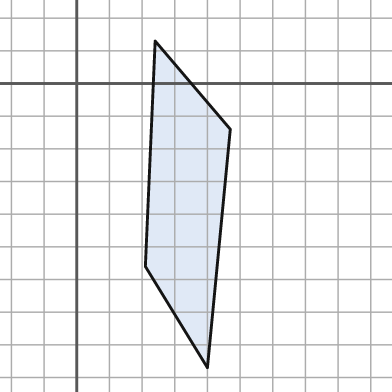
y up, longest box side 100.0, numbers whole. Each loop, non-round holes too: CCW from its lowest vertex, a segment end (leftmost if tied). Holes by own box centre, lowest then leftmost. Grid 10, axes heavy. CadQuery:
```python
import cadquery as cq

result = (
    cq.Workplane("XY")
    .moveTo(40.0, -87.0)
    .lineTo(47.0, -14.0)
    .lineTo(24.0, 13.0)
    .lineTo(21.0, -56.0)
    .close()
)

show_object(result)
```